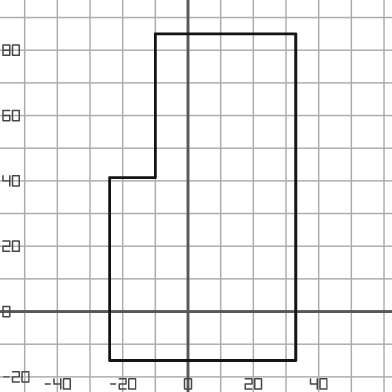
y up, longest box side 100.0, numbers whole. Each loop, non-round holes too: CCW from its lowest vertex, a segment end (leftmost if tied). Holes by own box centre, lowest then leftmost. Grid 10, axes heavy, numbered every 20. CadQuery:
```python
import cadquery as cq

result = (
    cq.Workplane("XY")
    .moveTo(-24.0, -15.0)
    .lineTo(33.0, -15.0)
    .lineTo(33.0, 85.0)
    .lineTo(-10.0, 85.0)
    .lineTo(-10.0, 41.0)
    .lineTo(-24.0, 41.0)
    .close()
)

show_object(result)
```